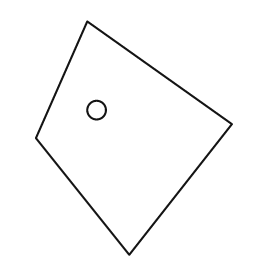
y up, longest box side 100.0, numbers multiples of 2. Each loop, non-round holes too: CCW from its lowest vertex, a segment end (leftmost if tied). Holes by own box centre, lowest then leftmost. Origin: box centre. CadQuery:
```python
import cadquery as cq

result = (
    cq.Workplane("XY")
    .moveTo(-2.0, -50.0)
    .lineTo(42.0, 6.0)
    .lineTo(-20.0, 50.0)
    .lineTo(-42.0, 0.0)
    .close()
    .moveTo(-16.0, 12.0)
    .circle(4.0)
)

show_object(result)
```